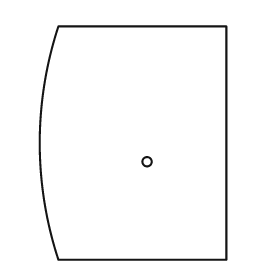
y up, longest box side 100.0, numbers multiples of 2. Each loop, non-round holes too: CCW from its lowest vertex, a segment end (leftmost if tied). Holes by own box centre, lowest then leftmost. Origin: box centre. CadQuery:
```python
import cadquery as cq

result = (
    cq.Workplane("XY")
    .moveTo(-32.0, -50.0)
    .lineTo(40.0, -50.0)
    .lineTo(40.0, 50.0)
    .lineTo(-32.0, 50.0)
    .threePointArc((-40.0, 0.0), (-32.0, -50.0))
    .close()
    .moveTo(6.0, -8.0)
    .circle(2.0)
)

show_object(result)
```